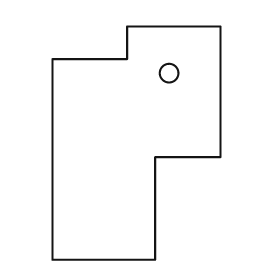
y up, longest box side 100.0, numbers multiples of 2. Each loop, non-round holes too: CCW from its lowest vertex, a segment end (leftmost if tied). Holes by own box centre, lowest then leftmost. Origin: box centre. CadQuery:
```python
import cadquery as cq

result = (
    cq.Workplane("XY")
    .moveTo(-36.0, -50.0)
    .lineTo(8.0, -50.0)
    .lineTo(8.0, -6.0)
    .lineTo(36.0, -6.0)
    .lineTo(36.0, 50.0)
    .lineTo(-4.0, 50.0)
    .lineTo(-4.0, 36.0)
    .lineTo(-36.0, 36.0)
    .close()
    .moveTo(14.0, 30.0)
    .circle(4.0)
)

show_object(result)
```